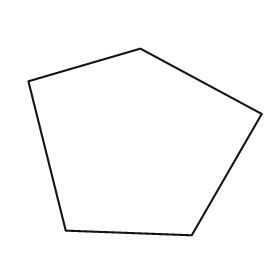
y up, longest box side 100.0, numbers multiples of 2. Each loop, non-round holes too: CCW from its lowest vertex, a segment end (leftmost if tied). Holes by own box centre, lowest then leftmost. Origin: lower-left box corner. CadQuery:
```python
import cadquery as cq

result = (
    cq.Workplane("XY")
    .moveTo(70.0, 0.0)
    .lineTo(100.0, 52.0)
    .lineTo(48.0, 80.0)
    .lineTo(0.0, 66.0)
    .lineTo(16.0, 2.0)
    .close()
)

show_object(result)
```